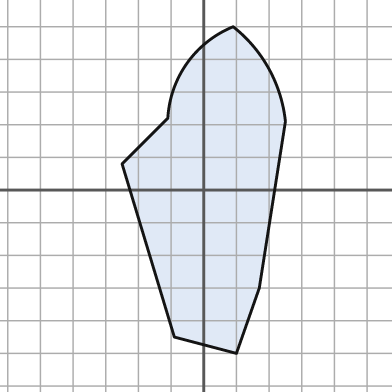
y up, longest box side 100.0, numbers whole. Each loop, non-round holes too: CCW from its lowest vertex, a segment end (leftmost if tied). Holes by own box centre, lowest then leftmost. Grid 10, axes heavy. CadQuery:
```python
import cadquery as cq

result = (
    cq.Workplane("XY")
    .moveTo(10.0, -50.0)
    .lineTo(17.0, -30.0)
    .lineTo(25.0, 21.0)
    .threePointArc((20.0, 37.0), (9.0, 50.0))
    .threePointArc((-5.0, 39.0), (-11.0, 22.0))
    .lineTo(-25.0, 8.0)
    .lineTo(-9.0, -45.0)
    .close()
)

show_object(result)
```